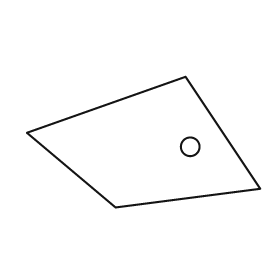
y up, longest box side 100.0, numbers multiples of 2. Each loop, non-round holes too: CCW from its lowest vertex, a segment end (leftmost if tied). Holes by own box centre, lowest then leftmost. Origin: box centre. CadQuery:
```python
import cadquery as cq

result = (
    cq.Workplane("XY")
    .moveTo(-12.0, -28.0)
    .lineTo(50.0, -20.0)
    .lineTo(18.0, 28.0)
    .lineTo(-50.0, 4.0)
    .close()
    .moveTo(20.0, -2.0)
    .circle(4.0)
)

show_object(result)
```